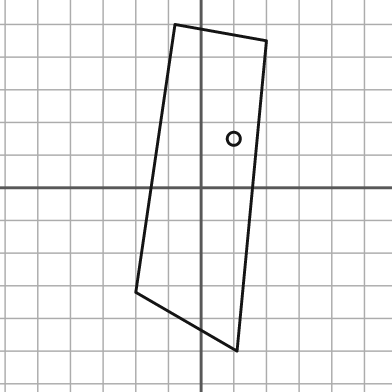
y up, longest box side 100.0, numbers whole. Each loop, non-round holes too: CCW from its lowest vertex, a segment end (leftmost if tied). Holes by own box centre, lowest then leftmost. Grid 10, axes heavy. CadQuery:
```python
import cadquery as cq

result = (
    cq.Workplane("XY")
    .moveTo(11.0, -50.0)
    .lineTo(20.0, 45.0)
    .lineTo(-8.0, 50.0)
    .lineTo(-20.0, -32.0)
    .close()
    .moveTo(10.0, 15.0)
    .circle(2.0)
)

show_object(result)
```